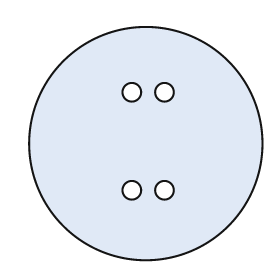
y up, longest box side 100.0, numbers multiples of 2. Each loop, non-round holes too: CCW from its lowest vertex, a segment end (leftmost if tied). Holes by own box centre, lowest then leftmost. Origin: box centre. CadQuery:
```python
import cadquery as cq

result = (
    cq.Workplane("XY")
    .moveTo(0.0, 0.0)
    .circle(50.0)
    .moveTo(-6.0, -20.0)
    .circle(4.0)
    .moveTo(8.0, -20.0)
    .circle(4.0)
    .moveTo(-6.0, 22.0)
    .circle(4.0)
    .moveTo(8.0, 22.0)
    .circle(4.0)
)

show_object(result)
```